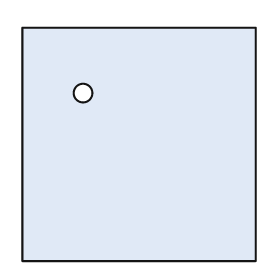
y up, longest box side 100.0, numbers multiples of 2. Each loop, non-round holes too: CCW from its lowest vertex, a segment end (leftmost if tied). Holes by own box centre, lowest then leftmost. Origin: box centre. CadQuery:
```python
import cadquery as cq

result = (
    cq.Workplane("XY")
    .moveTo(-50.0, -50.0)
    .lineTo(50.0, -50.0)
    .lineTo(50.0, 50.0)
    .lineTo(-50.0, 50.0)
    .close()
    .moveTo(-24.0, 22.0)
    .circle(4.0)
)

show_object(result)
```